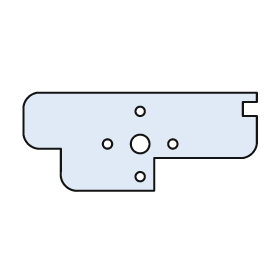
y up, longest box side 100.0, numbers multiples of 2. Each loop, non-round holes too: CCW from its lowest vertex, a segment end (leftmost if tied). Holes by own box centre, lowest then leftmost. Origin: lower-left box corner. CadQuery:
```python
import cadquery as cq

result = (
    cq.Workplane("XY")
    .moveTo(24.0, 0.0)
    .lineTo(56.0, 0.0)
    .lineTo(56.0, 14.0)
    .lineTo(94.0, 14.0)
    .threePointArc((98.0, 16.0), (100.0, 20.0))
    .lineTo(100.0, 32.0)
    .lineTo(94.0, 32.0)
    .lineTo(94.0, 38.0)
    .lineTo(100.0, 38.0)
    .lineTo(100.0, 42.0)
    .lineTo(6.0, 42.0)
    .threePointArc((2.0, 40.0), (0.0, 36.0))
    .lineTo(0.0, 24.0)
    .threePointArc((2.0, 20.0), (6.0, 18.0))
    .lineTo(16.0, 18.0)
    .lineTo(16.0, 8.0)
    .threePointArc((18.0, 2.0), (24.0, 0.0))
    .close()
    .moveTo(50.0, 6.0)
    .circle(2.0)
    .moveTo(36.0, 20.0)
    .circle(2.0)
    .moveTo(50.0, 20.0)
    .circle(4.0)
    .moveTo(64.0, 20.0)
    .circle(2.0)
    .moveTo(50.0, 34.0)
    .circle(2.0)
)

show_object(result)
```